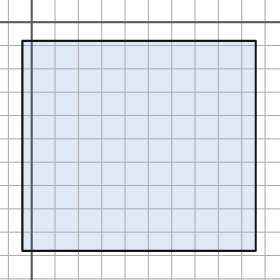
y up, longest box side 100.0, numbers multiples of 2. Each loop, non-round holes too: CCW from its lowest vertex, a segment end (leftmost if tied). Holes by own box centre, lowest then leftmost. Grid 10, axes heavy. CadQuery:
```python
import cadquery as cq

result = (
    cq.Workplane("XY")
    .moveTo(-4.0, -98.0)
    .lineTo(96.0, -98.0)
    .lineTo(96.0, -8.0)
    .lineTo(-4.0, -8.0)
    .close()
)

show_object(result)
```